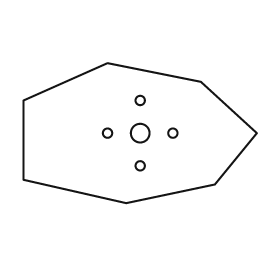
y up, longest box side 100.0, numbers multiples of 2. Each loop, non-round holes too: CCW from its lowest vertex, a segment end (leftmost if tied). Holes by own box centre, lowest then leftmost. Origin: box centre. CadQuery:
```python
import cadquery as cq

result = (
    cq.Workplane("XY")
    .moveTo(-6.0, -30.0)
    .lineTo(32.0, -22.0)
    .lineTo(50.0, 0.0)
    .lineTo(26.0, 22.0)
    .lineTo(-14.0, 30.0)
    .lineTo(-50.0, 14.0)
    .lineTo(-50.0, -20.0)
    .close()
    .moveTo(0.0, -14.0)
    .circle(2.0)
    .moveTo(-14.0, 0.0)
    .circle(2.0)
    .moveTo(0.0, 0.0)
    .circle(4.0)
    .moveTo(14.0, 0.0)
    .circle(2.0)
    .moveTo(0.0, 14.0)
    .circle(2.0)
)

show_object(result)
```